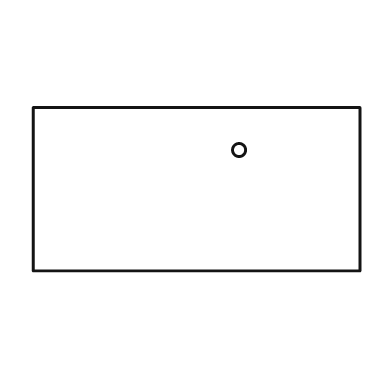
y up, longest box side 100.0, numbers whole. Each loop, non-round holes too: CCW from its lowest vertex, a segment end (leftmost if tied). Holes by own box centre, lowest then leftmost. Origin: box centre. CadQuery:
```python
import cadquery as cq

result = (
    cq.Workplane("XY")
    .moveTo(-50.0, -25.0)
    .lineTo(50.0, -25.0)
    .lineTo(50.0, 25.0)
    .lineTo(-50.0, 25.0)
    .close()
    .moveTo(13.0, 12.0)
    .circle(2.0)
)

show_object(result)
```